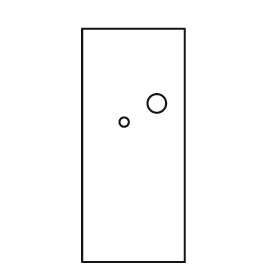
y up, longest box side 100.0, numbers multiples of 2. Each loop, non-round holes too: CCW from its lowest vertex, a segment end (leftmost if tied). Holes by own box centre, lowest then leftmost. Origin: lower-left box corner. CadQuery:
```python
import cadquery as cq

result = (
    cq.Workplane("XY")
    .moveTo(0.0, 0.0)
    .lineTo(44.0, 0.0)
    .lineTo(44.0, 100.0)
    .lineTo(0.0, 100.0)
    .close()
    .moveTo(18.0, 60.0)
    .circle(2.0)
    .moveTo(32.0, 68.0)
    .circle(4.0)
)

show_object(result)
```